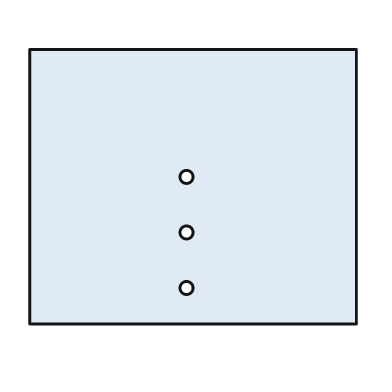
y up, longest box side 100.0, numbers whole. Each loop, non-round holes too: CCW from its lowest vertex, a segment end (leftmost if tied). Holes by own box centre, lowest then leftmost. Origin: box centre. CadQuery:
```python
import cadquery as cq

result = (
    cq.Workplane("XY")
    .moveTo(-50.0, -42.0)
    .lineTo(50.0, -42.0)
    .lineTo(50.0, 42.0)
    .lineTo(-50.0, 42.0)
    .close()
    .moveTo(-2.0, -31.0)
    .circle(2.0)
    .moveTo(-2.0, -14.0)
    .circle(2.0)
    .moveTo(-2.0, 3.0)
    .circle(2.0)
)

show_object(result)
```